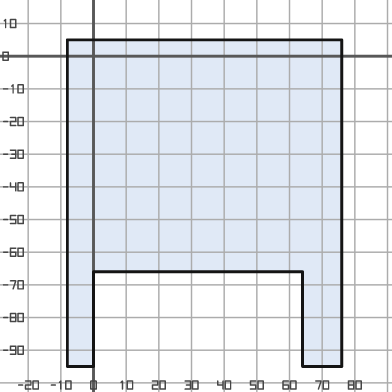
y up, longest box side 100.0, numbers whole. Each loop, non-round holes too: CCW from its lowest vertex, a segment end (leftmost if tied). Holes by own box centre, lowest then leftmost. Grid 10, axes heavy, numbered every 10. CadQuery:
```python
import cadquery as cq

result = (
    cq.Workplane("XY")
    .moveTo(-8.0, -95.0)
    .lineTo(0.0, -95.0)
    .lineTo(0.0, -66.0)
    .lineTo(64.0, -66.0)
    .lineTo(64.0, -95.0)
    .lineTo(76.0, -95.0)
    .lineTo(76.0, 5.0)
    .lineTo(-8.0, 5.0)
    .close()
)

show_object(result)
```